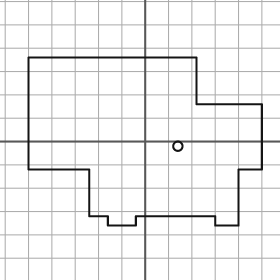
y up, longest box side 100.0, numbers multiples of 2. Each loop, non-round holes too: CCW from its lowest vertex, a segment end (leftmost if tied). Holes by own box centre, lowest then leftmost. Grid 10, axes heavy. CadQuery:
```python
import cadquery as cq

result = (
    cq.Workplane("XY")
    .moveTo(-16.0, -36.0)
    .lineTo(-4.0, -36.0)
    .lineTo(-4.0, -32.0)
    .lineTo(30.0, -32.0)
    .lineTo(30.0, -36.0)
    .lineTo(40.0, -36.0)
    .lineTo(40.0, -12.0)
    .lineTo(50.0, -12.0)
    .lineTo(50.0, 16.0)
    .lineTo(22.0, 16.0)
    .lineTo(22.0, 36.0)
    .lineTo(-50.0, 36.0)
    .lineTo(-50.0, -12.0)
    .lineTo(-24.0, -12.0)
    .lineTo(-24.0, -32.0)
    .lineTo(-16.0, -32.0)
    .close()
    .moveTo(14.0, -2.0)
    .circle(2.0)
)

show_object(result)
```